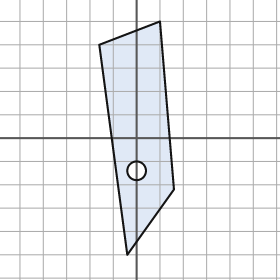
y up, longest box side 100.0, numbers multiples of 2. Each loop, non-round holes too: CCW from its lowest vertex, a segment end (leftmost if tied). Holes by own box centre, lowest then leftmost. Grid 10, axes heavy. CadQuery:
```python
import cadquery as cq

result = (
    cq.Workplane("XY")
    .moveTo(-4.0, -50.0)
    .lineTo(16.0, -22.0)
    .lineTo(10.0, 50.0)
    .lineTo(-16.0, 40.0)
    .close()
    .moveTo(0.0, -14.0)
    .circle(4.0)
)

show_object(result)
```